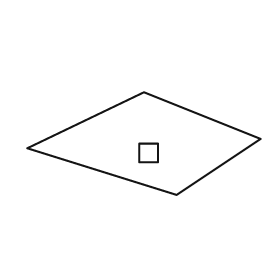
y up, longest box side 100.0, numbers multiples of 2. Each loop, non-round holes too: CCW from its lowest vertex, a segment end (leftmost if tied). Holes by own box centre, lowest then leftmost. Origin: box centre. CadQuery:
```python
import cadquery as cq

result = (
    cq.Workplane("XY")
    .moveTo(14.0, -22.0)
    .lineTo(50.0, 2.0)
    .lineTo(0.0, 22.0)
    .lineTo(-50.0, -2.0)
    .close()
    .moveTo(-2.0, -8.0)
    .lineTo(6.0, -8.0)
    .lineTo(6.0, 0.0)
    .lineTo(-2.0, 0.0)
    .close()
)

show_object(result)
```